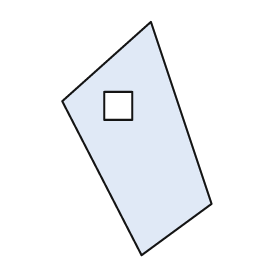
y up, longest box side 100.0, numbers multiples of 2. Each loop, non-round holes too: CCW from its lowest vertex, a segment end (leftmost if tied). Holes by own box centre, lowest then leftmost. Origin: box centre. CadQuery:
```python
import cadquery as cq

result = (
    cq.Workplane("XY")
    .moveTo(2.0, -50.0)
    .lineTo(32.0, -28.0)
    .lineTo(6.0, 50.0)
    .lineTo(-32.0, 16.0)
    .close()
    .moveTo(-14.0, 8.0)
    .lineTo(-2.0, 8.0)
    .lineTo(-2.0, 20.0)
    .lineTo(-14.0, 20.0)
    .close()
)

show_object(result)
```